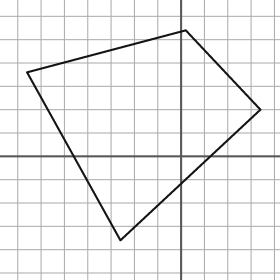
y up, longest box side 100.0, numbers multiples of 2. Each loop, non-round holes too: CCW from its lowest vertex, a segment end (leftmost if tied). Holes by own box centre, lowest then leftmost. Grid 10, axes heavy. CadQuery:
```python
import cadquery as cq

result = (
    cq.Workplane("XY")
    .moveTo(-26.0, -36.0)
    .lineTo(34.0, 20.0)
    .lineTo(2.0, 54.0)
    .lineTo(-66.0, 36.0)
    .close()
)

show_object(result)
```